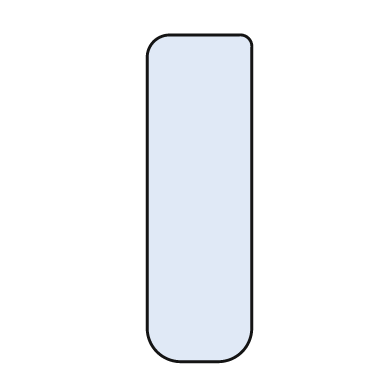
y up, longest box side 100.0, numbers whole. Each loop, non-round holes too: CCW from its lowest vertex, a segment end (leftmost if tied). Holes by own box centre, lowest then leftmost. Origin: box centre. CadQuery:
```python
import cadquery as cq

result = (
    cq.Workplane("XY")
    .moveTo(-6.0, -50.0)
    .lineTo(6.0, -50.0)
    .threePointArc((13.0, -47.0), (16.0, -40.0))
    .lineTo(16.0, 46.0)
    .threePointArc((15.0, 49.0), (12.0, 50.0))
    .lineTo(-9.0, 50.0)
    .threePointArc((-14.0, 48.0), (-16.0, 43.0))
    .lineTo(-16.0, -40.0)
    .threePointArc((-13.0, -47.0), (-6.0, -50.0))
    .close()
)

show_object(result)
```